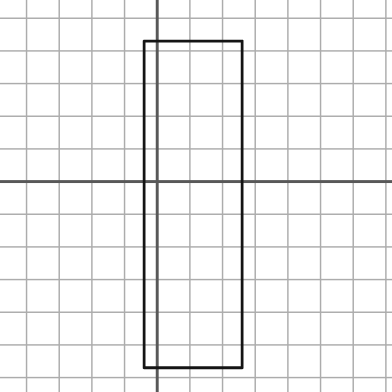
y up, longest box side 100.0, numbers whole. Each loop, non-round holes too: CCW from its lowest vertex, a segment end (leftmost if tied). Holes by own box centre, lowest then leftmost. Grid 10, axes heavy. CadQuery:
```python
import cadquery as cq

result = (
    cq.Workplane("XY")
    .moveTo(-4.0, -57.0)
    .lineTo(26.0, -57.0)
    .lineTo(26.0, 43.0)
    .lineTo(-4.0, 43.0)
    .close()
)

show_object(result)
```